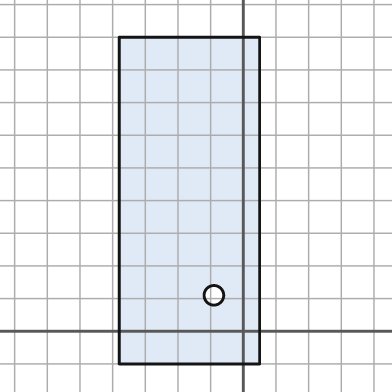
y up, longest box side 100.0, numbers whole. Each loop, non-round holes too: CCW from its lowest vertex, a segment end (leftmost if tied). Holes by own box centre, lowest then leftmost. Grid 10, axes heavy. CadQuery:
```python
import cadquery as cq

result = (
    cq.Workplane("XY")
    .moveTo(-38.0, -10.0)
    .lineTo(5.0, -10.0)
    .lineTo(5.0, 90.0)
    .lineTo(-38.0, 90.0)
    .close()
    .moveTo(-9.0, 11.0)
    .circle(3.0)
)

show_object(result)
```